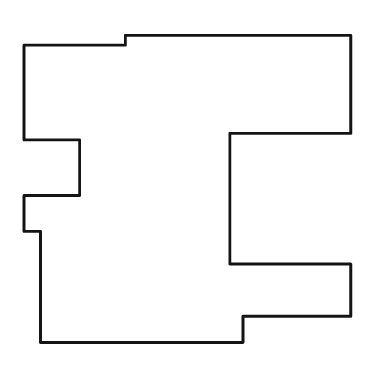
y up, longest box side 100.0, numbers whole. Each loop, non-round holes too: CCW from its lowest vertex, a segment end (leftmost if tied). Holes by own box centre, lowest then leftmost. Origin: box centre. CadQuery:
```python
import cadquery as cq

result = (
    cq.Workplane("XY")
    .moveTo(-45.0, -47.0)
    .lineTo(17.0, -47.0)
    .lineTo(17.0, -39.0)
    .lineTo(50.0, -39.0)
    .lineTo(50.0, -23.0)
    .lineTo(13.0, -23.0)
    .lineTo(13.0, 17.0)
    .lineTo(50.0, 17.0)
    .lineTo(50.0, 47.0)
    .lineTo(-19.0, 47.0)
    .lineTo(-19.0, 44.0)
    .lineTo(-50.0, 44.0)
    .lineTo(-50.0, 15.0)
    .lineTo(-33.0, 15.0)
    .lineTo(-33.0, -2.0)
    .lineTo(-50.0, -2.0)
    .lineTo(-50.0, -13.0)
    .lineTo(-45.0, -13.0)
    .close()
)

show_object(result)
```